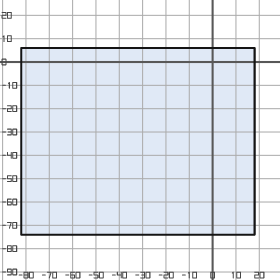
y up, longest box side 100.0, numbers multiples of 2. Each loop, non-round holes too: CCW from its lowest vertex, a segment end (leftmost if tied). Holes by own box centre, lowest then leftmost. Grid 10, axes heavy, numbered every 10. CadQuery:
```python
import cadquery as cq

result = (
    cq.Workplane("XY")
    .moveTo(-82.0, -74.0)
    .lineTo(18.0, -74.0)
    .lineTo(18.0, 6.0)
    .lineTo(-82.0, 6.0)
    .close()
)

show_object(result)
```